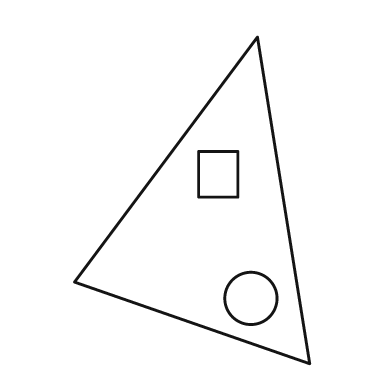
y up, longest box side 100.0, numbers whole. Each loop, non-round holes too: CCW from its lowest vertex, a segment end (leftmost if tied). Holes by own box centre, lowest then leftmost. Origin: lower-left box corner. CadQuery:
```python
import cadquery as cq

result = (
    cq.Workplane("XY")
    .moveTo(72.0, 0.0)
    .lineTo(56.0, 100.0)
    .lineTo(0.0, 25.0)
    .close()
    .moveTo(54.0, 20.0)
    .circle(8.0)
    .moveTo(38.0, 51.0)
    .lineTo(50.0, 51.0)
    .lineTo(50.0, 65.0)
    .lineTo(38.0, 65.0)
    .close()
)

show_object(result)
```